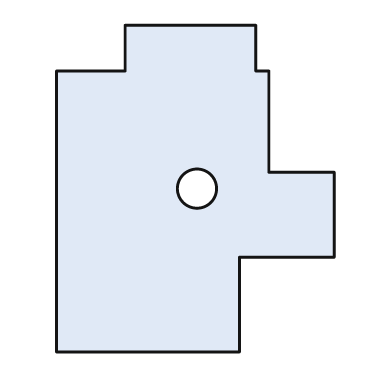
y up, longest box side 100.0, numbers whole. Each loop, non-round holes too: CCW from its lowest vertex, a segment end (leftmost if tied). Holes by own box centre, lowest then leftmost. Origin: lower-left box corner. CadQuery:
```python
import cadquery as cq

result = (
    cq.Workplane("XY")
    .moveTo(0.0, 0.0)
    .lineTo(56.0, 0.0)
    .lineTo(56.0, 29.0)
    .lineTo(85.0, 29.0)
    .lineTo(85.0, 55.0)
    .lineTo(65.0, 55.0)
    .lineTo(65.0, 86.0)
    .lineTo(61.0, 86.0)
    .lineTo(61.0, 100.0)
    .lineTo(21.0, 100.0)
    .lineTo(21.0, 86.0)
    .lineTo(0.0, 86.0)
    .close()
    .moveTo(43.0, 50.0)
    .circle(6.0)
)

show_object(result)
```